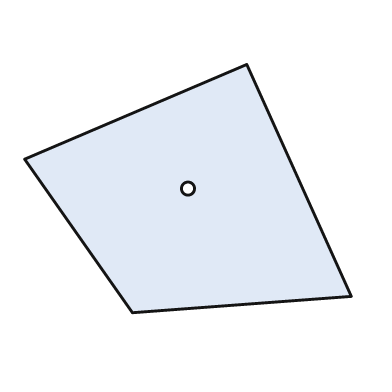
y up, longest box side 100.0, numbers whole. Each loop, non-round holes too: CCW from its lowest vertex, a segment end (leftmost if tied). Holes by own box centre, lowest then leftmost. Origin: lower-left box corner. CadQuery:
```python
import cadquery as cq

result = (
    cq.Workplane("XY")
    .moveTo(33.0, 0.0)
    .lineTo(100.0, 5.0)
    .lineTo(68.0, 76.0)
    .lineTo(0.0, 47.0)
    .close()
    .moveTo(50.0, 38.0)
    .circle(2.0)
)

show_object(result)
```